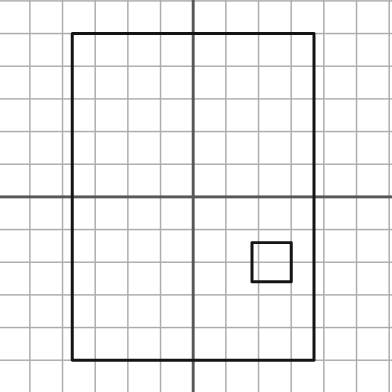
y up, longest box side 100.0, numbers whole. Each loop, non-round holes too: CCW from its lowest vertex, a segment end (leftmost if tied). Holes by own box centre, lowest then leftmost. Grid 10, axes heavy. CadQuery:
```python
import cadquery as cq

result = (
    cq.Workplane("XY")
    .moveTo(-37.0, -50.0)
    .lineTo(37.0, -50.0)
    .lineTo(37.0, 50.0)
    .lineTo(-37.0, 50.0)
    .close()
    .moveTo(18.0, -26.0)
    .lineTo(30.0, -26.0)
    .lineTo(30.0, -14.0)
    .lineTo(18.0, -14.0)
    .close()
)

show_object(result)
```